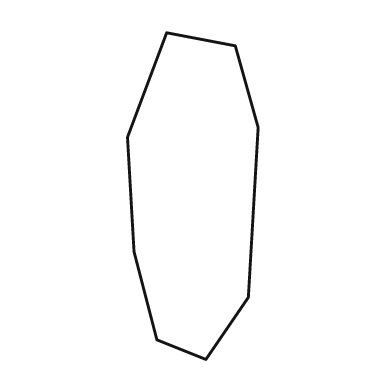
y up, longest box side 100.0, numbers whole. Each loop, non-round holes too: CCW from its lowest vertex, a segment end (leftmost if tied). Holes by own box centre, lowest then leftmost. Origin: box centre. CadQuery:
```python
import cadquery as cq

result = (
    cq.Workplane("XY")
    .moveTo(4.0, -50.0)
    .lineTo(17.0, -31.0)
    .lineTo(20.0, 21.0)
    .lineTo(13.0, 46.0)
    .lineTo(-8.0, 50.0)
    .lineTo(-20.0, 18.0)
    .lineTo(-18.0, -17.0)
    .lineTo(-11.0, -44.0)
    .close()
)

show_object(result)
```